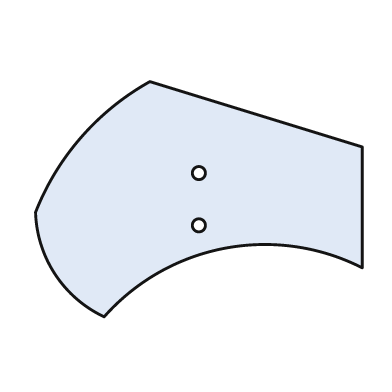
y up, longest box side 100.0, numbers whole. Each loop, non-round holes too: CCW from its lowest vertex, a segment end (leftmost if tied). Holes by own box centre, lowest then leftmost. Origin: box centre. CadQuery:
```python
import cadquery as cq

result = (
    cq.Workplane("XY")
    .moveTo(-29.0, -36.0)
    .threePointArc((8.0, -15.0), (50.0, -21.0))
    .lineTo(50.0, 16.0)
    .lineTo(-15.0, 36.0)
    .threePointArc((-36.0, 19.0), (-50.0, -4.0))
    .threePointArc((-44.0, -23.0), (-29.0, -36.0))
    .close()
    .moveTo(0.0, -8.0)
    .circle(2.0)
    .moveTo(0.0, 8.0)
    .circle(2.0)
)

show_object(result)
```